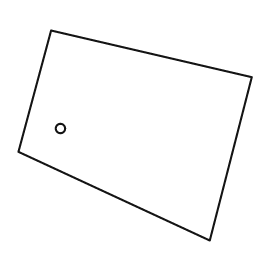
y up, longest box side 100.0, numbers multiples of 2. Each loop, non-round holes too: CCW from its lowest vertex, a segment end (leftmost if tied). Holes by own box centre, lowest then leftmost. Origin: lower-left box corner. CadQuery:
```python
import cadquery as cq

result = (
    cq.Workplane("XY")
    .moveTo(82.0, 0.0)
    .lineTo(100.0, 70.0)
    .lineTo(14.0, 90.0)
    .lineTo(0.0, 38.0)
    .close()
    .moveTo(18.0, 48.0)
    .circle(2.0)
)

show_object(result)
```